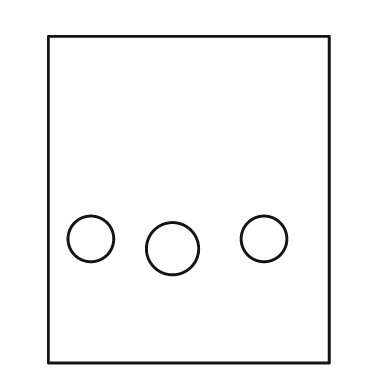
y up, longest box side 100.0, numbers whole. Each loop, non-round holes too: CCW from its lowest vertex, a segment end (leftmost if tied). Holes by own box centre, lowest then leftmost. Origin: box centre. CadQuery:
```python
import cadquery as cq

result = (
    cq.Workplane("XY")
    .moveTo(-43.0, -50.0)
    .lineTo(43.0, -50.0)
    .lineTo(43.0, 50.0)
    .lineTo(-43.0, 50.0)
    .close()
    .moveTo(-5.0, -15.0)
    .circle(8.0)
    .moveTo(-30.0, -12.0)
    .circle(7.0)
    .moveTo(23.0, -12.0)
    .circle(7.0)
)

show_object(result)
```